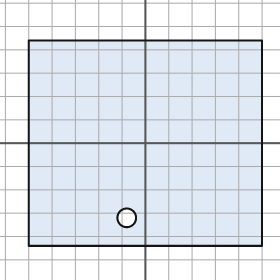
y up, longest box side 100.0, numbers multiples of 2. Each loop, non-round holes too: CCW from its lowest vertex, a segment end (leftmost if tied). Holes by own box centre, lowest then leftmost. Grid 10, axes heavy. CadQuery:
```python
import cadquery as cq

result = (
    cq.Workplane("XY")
    .moveTo(-50.0, -44.0)
    .lineTo(50.0, -44.0)
    .lineTo(50.0, 44.0)
    .lineTo(-50.0, 44.0)
    .close()
    .moveTo(-8.0, -32.0)
    .circle(4.0)
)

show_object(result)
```